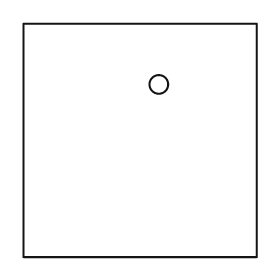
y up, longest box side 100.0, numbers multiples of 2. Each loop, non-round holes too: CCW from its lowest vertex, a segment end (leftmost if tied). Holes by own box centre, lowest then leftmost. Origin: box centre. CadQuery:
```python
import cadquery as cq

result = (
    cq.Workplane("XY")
    .moveTo(-50.0, -50.0)
    .lineTo(50.0, -50.0)
    .lineTo(50.0, 50.0)
    .lineTo(-50.0, 50.0)
    .close()
    .moveTo(8.0, 24.0)
    .circle(4.0)
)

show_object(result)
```